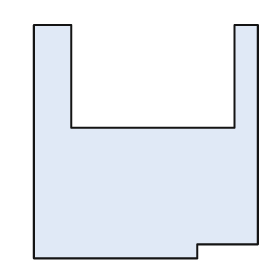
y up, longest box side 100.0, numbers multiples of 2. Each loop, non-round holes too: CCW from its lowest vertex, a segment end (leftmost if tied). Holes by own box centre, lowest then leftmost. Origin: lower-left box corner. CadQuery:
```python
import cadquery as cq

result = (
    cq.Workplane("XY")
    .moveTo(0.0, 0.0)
    .lineTo(70.0, 0.0)
    .lineTo(70.0, 6.0)
    .lineTo(96.0, 6.0)
    .lineTo(96.0, 100.0)
    .lineTo(86.0, 100.0)
    .lineTo(86.0, 56.0)
    .lineTo(16.0, 56.0)
    .lineTo(16.0, 100.0)
    .lineTo(0.0, 100.0)
    .close()
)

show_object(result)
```